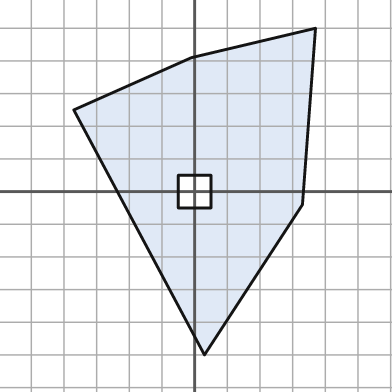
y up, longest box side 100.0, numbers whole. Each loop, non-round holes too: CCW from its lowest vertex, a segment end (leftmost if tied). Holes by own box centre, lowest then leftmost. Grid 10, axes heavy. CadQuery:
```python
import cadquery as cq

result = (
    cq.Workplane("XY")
    .moveTo(3.0, -50.0)
    .lineTo(33.0, -4.0)
    .lineTo(37.0, 50.0)
    .lineTo(-1.0, 41.0)
    .lineTo(-37.0, 25.0)
    .close()
    .moveTo(-5.0, -5.0)
    .lineTo(5.0, -5.0)
    .lineTo(5.0, 5.0)
    .lineTo(-5.0, 5.0)
    .close()
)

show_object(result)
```